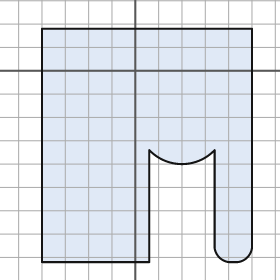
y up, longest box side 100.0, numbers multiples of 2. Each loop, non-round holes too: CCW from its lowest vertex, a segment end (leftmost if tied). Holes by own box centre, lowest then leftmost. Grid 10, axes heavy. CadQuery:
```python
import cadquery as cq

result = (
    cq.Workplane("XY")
    .moveTo(-40.0, -82.0)
    .lineTo(6.0, -82.0)
    .lineTo(6.0, -34.0)
    .threePointArc((20.0, -40.0), (34.0, -34.0))
    .lineTo(34.0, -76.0)
    .threePointArc((36.0, -80.0), (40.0, -82.0))
    .lineTo(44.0, -82.0)
    .threePointArc((48.0, -80.0), (50.0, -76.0))
    .lineTo(50.0, 18.0)
    .lineTo(-40.0, 18.0)
    .close()
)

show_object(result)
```